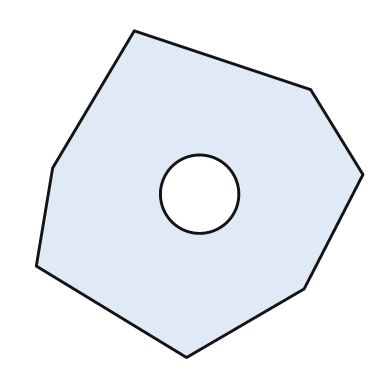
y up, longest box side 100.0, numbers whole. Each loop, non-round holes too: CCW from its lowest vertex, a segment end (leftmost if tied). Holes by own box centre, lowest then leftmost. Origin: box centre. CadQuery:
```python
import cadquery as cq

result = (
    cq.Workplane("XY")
    .moveTo(-4.0, -50.0)
    .lineTo(32.0, -29.0)
    .lineTo(50.0, 6.0)
    .lineTo(34.0, 32.0)
    .lineTo(-20.0, 50.0)
    .lineTo(-45.0, 8.0)
    .lineTo(-50.0, -22.0)
    .close()
    .moveTo(0.0, 0.0)
    .circle(12.0)
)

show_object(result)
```